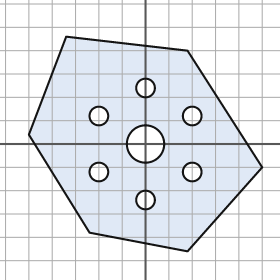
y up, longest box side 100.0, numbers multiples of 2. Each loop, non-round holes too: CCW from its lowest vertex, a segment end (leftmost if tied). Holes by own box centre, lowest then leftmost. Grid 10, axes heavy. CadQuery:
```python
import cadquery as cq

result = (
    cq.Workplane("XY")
    .moveTo(18.0, -46.0)
    .lineTo(50.0, -10.0)
    .lineTo(18.0, 40.0)
    .lineTo(-34.0, 46.0)
    .lineTo(-50.0, 4.0)
    .lineTo(-24.0, -38.0)
    .close()
    .moveTo(0.0, -24.0)
    .circle(4.0)
    .moveTo(-20.0, -12.0)
    .circle(4.0)
    .moveTo(20.0, -12.0)
    .circle(4.0)
    .moveTo(0.0, 0.0)
    .circle(8.0)
    .moveTo(-20.0, 12.0)
    .circle(4.0)
    .moveTo(20.0, 12.0)
    .circle(4.0)
    .moveTo(0.0, 24.0)
    .circle(4.0)
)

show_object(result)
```